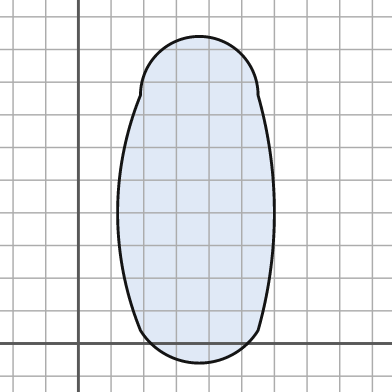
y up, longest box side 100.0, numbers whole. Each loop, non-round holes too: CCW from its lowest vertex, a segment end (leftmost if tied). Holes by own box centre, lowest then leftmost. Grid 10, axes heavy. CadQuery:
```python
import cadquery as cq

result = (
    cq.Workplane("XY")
    .moveTo(19.0, 4.0)
    .threePointArc((37.0, -6.0), (55.0, 4.0))
    .threePointArc((60.0, 40.0), (55.0, 76.0))
    .threePointArc((37.0, 94.0), (19.0, 76.0))
    .threePointArc((12.0, 40.0), (19.0, 4.0))
    .close()
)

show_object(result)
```